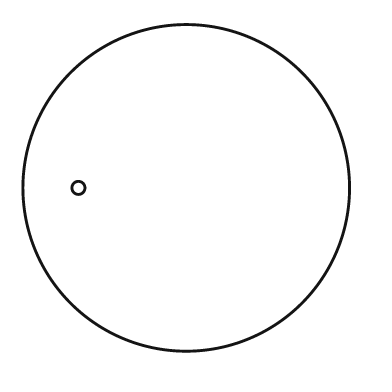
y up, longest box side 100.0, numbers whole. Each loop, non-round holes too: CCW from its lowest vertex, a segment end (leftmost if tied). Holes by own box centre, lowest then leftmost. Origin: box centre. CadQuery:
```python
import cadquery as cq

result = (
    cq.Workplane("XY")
    .moveTo(0.0, 0.0)
    .circle(50.0)
    .moveTo(-33.0, 0.0)
    .circle(2.0)
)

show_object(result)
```